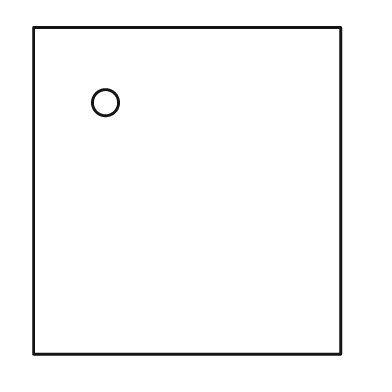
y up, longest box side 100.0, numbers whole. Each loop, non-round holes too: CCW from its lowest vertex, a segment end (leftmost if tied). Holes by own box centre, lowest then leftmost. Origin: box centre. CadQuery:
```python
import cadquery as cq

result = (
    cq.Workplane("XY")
    .moveTo(-47.0, -50.0)
    .lineTo(47.0, -50.0)
    .lineTo(47.0, 50.0)
    .lineTo(-47.0, 50.0)
    .close()
    .moveTo(-25.0, 27.0)
    .circle(4.0)
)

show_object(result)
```